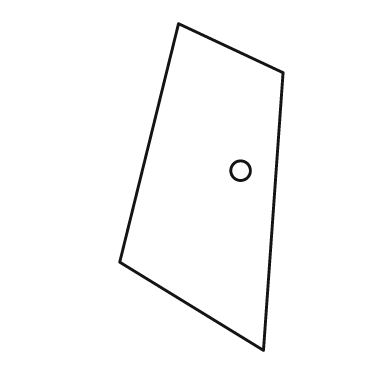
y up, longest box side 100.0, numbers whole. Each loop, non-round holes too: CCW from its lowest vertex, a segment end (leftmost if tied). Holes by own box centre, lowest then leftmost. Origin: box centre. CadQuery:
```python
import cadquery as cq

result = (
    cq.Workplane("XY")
    .moveTo(19.0, -50.0)
    .lineTo(25.0, 35.0)
    .lineTo(-7.0, 50.0)
    .lineTo(-25.0, -23.0)
    .close()
    .moveTo(12.0, 5.0)
    .circle(3.0)
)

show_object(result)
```